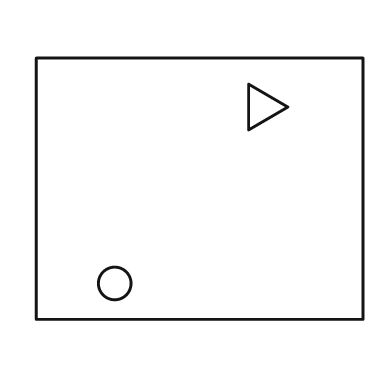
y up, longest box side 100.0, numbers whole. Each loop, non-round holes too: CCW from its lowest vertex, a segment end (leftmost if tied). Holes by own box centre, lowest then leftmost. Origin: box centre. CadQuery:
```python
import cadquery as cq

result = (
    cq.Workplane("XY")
    .moveTo(-50.0, -40.0)
    .lineTo(50.0, -40.0)
    .lineTo(50.0, 40.0)
    .lineTo(-50.0, 40.0)
    .close()
    .moveTo(-26.0, -29.0)
    .circle(5.0)
    .moveTo(15.0, 18.0)
    .lineTo(27.0, 25.0)
    .lineTo(15.0, 32.0)
    .close()
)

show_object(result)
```